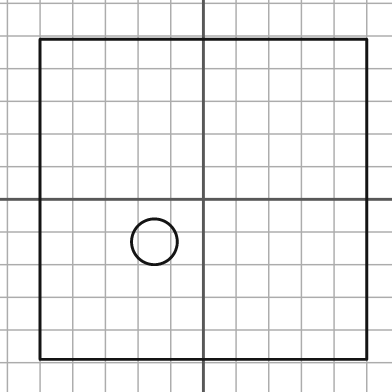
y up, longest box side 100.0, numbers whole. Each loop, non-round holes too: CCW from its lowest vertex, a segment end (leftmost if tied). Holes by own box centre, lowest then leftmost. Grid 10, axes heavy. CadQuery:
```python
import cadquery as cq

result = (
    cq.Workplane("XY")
    .moveTo(-50.0, -49.0)
    .lineTo(50.0, -49.0)
    .lineTo(50.0, 49.0)
    .lineTo(-50.0, 49.0)
    .close()
    .moveTo(-15.0, -13.0)
    .circle(7.0)
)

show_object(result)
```